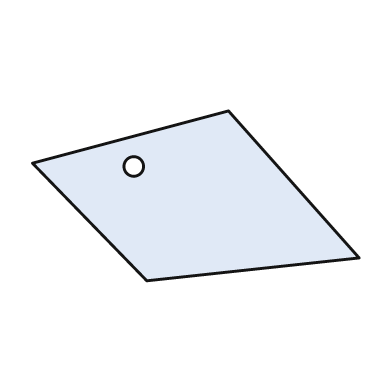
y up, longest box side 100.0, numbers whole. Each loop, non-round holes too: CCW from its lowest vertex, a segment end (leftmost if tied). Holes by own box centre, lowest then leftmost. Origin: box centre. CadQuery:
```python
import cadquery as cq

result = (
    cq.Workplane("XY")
    .moveTo(-15.0, -26.0)
    .lineTo(50.0, -19.0)
    .lineTo(10.0, 26.0)
    .lineTo(-50.0, 10.0)
    .close()
    .moveTo(-19.0, 9.0)
    .circle(3.0)
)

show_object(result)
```